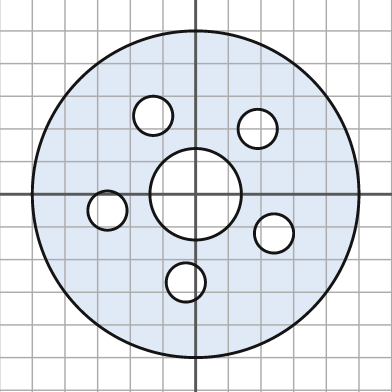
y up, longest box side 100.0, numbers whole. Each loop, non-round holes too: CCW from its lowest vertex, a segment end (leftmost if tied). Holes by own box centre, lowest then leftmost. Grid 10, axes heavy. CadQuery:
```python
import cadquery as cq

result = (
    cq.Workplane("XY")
    .moveTo(0.0, 0.0)
    .circle(50.0)
    .moveTo(-3.0, -27.0)
    .circle(6.0)
    .moveTo(24.0, -12.0)
    .circle(6.0)
    .moveTo(-27.0, -5.0)
    .circle(6.0)
    .moveTo(0.0, 0.0)
    .circle(14.0)
    .moveTo(19.0, 20.0)
    .circle(6.0)
    .moveTo(-13.0, 24.0)
    .circle(6.0)
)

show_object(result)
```